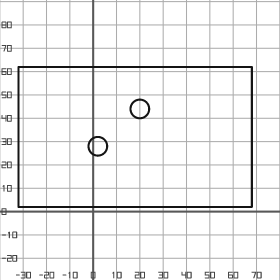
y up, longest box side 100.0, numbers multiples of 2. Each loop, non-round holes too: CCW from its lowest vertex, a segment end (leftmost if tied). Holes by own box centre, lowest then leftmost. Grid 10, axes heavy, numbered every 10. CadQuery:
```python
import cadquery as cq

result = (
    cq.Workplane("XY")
    .moveTo(-32.0, 2.0)
    .lineTo(68.0, 2.0)
    .lineTo(68.0, 62.0)
    .lineTo(-32.0, 62.0)
    .close()
    .moveTo(2.0, 28.0)
    .circle(4.0)
    .moveTo(20.0, 44.0)
    .circle(4.0)
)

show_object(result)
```